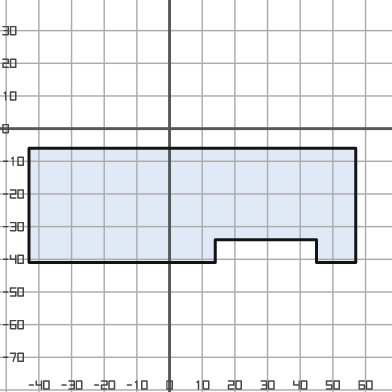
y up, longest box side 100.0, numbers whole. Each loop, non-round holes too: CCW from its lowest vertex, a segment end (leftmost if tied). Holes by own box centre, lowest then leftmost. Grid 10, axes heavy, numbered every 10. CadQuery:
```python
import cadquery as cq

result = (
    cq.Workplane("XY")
    .moveTo(-43.0, -41.0)
    .lineTo(14.0, -41.0)
    .lineTo(14.0, -34.0)
    .lineTo(45.0, -34.0)
    .lineTo(45.0, -41.0)
    .lineTo(57.0, -41.0)
    .lineTo(57.0, -6.0)
    .lineTo(-43.0, -6.0)
    .close()
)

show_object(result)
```